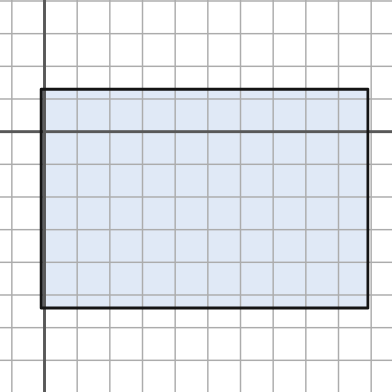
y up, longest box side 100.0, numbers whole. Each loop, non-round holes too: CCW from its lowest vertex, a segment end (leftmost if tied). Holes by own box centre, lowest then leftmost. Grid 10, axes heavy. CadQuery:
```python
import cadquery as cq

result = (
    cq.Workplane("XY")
    .moveTo(-1.0, -54.0)
    .lineTo(99.0, -54.0)
    .lineTo(99.0, 13.0)
    .lineTo(-1.0, 13.0)
    .close()
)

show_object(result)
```